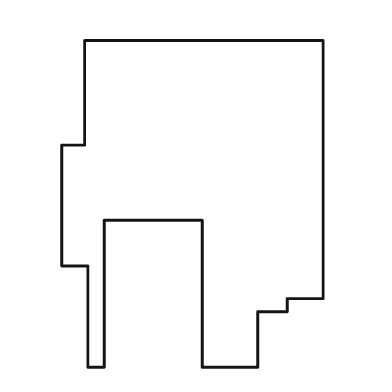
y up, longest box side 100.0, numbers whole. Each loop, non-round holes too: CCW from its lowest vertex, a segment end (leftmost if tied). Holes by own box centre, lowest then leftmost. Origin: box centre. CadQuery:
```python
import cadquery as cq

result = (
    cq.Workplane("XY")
    .moveTo(-32.0, -50.0)
    .lineTo(-27.0, -50.0)
    .lineTo(-27.0, -5.0)
    .lineTo(3.0, -5.0)
    .lineTo(3.0, -50.0)
    .lineTo(20.0, -50.0)
    .lineTo(20.0, -33.0)
    .lineTo(29.0, -33.0)
    .lineTo(29.0, -29.0)
    .lineTo(40.0, -29.0)
    .lineTo(40.0, 50.0)
    .lineTo(-33.0, 50.0)
    .lineTo(-33.0, 18.0)
    .lineTo(-40.0, 18.0)
    .lineTo(-40.0, -19.0)
    .lineTo(-32.0, -19.0)
    .close()
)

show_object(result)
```